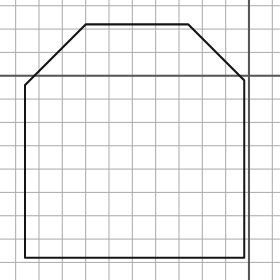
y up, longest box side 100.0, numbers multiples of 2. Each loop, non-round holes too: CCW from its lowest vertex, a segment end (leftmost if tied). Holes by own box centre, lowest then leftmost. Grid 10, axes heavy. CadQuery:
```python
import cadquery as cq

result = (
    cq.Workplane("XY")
    .moveTo(-96.0, -78.0)
    .lineTo(-2.0, -78.0)
    .lineTo(-2.0, -2.0)
    .lineTo(-26.0, 22.0)
    .lineTo(-70.0, 22.0)
    .lineTo(-96.0, -4.0)
    .close()
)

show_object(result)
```